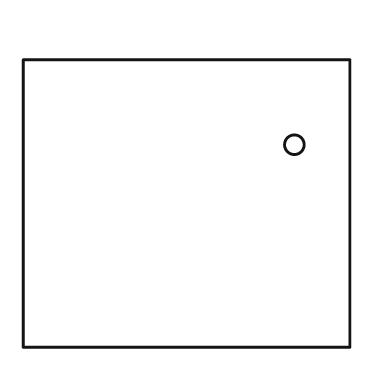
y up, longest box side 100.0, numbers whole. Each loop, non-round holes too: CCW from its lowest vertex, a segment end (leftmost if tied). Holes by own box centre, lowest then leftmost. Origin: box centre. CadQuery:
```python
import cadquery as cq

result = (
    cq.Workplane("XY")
    .moveTo(-50.0, -44.0)
    .lineTo(50.0, -44.0)
    .lineTo(50.0, 44.0)
    .lineTo(-50.0, 44.0)
    .close()
    .moveTo(33.0, 18.0)
    .circle(3.0)
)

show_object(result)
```